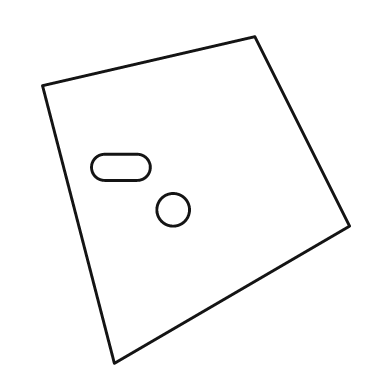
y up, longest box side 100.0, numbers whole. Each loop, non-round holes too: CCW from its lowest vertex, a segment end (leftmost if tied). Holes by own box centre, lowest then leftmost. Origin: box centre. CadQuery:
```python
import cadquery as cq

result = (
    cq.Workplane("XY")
    .moveTo(-25.0, -50.0)
    .lineTo(47.0, -8.0)
    .lineTo(18.0, 50.0)
    .lineTo(-47.0, 35.0)
    .close()
    .moveTo(-7.0, -3.0)
    .circle(5.0)
    .moveTo(-28.0, 6.0)
    .lineTo(-18.0, 6.0)
    .threePointArc((-14.0, 10.0), (-18.0, 14.0))
    .lineTo(-28.0, 14.0)
    .threePointArc((-32.0, 10.0), (-28.0, 6.0))
    .close()
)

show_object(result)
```